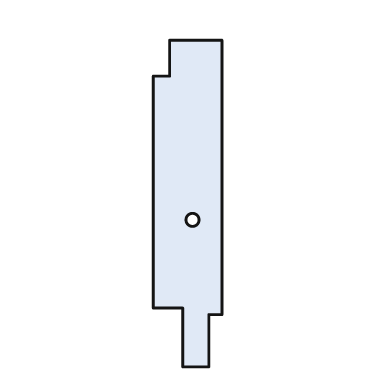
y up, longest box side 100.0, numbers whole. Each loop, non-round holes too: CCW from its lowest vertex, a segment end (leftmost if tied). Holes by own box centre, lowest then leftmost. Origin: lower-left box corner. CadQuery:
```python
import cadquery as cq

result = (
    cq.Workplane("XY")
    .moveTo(9.0, 0.0)
    .lineTo(17.0, 0.0)
    .lineTo(17.0, 16.0)
    .lineTo(21.0, 16.0)
    .lineTo(21.0, 100.0)
    .lineTo(5.0, 100.0)
    .lineTo(5.0, 89.0)
    .lineTo(0.0, 89.0)
    .lineTo(0.0, 18.0)
    .lineTo(9.0, 18.0)
    .close()
    .moveTo(12.0, 45.0)
    .circle(2.0)
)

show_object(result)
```